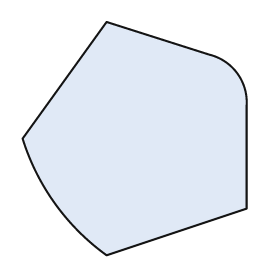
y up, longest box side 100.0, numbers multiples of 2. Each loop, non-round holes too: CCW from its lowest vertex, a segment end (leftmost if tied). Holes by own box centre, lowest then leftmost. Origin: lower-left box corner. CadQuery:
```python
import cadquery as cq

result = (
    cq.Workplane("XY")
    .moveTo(36.0, 0.0)
    .lineTo(96.0, 20.0)
    .lineTo(96.0, 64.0)
    .threePointArc((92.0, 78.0), (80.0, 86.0))
    .lineTo(36.0, 100.0)
    .lineTo(0.0, 50.0)
    .threePointArc((14.0, 22.0), (36.0, 0.0))
    .close()
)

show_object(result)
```